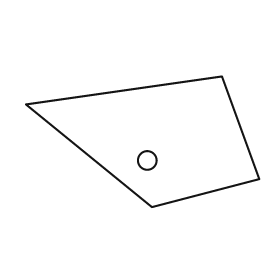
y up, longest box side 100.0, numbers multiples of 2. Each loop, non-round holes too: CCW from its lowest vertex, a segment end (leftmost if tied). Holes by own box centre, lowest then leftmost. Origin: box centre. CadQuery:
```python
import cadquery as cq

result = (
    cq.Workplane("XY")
    .moveTo(4.0, -28.0)
    .lineTo(50.0, -16.0)
    .lineTo(34.0, 28.0)
    .lineTo(-50.0, 16.0)
    .close()
    .moveTo(2.0, -8.0)
    .circle(4.0)
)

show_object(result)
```